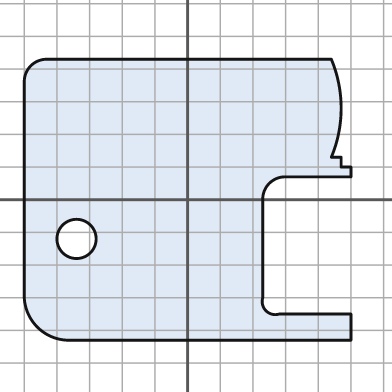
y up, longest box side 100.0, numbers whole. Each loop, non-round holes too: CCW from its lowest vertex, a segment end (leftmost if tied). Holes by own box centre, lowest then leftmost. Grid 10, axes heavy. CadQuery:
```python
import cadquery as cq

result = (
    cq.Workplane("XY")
    .moveTo(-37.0, -43.0)
    .lineTo(50.0, -43.0)
    .lineTo(50.0, -35.0)
    .lineTo(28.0, -35.0)
    .threePointArc((24.0, -34.0), (23.0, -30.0))
    .lineTo(23.0, 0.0)
    .threePointArc((25.0, 5.0), (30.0, 7.0))
    .lineTo(50.0, 7.0)
    .lineTo(50.0, 10.0)
    .lineTo(47.0, 10.0)
    .lineTo(47.0, 13.0)
    .lineTo(44.0, 13.0)
    .threePointArc((47.0, 28.0), (44.0, 43.0))
    .lineTo(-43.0, 43.0)
    .threePointArc((-48.0, 41.0), (-50.0, 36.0))
    .lineTo(-50.0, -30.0)
    .threePointArc((-46.0, -39.0), (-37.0, -43.0))
    .close()
    .moveTo(-34.0, -12.0)
    .circle(6.0)
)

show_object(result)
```